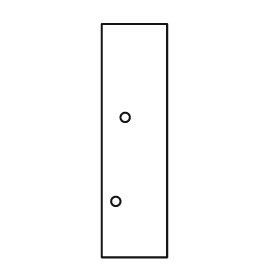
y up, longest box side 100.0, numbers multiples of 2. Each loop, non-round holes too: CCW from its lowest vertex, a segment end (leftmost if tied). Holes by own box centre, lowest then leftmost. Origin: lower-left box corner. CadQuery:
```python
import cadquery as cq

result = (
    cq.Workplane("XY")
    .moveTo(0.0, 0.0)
    .lineTo(28.0, 0.0)
    .lineTo(28.0, 100.0)
    .lineTo(0.0, 100.0)
    .close()
    .moveTo(6.0, 24.0)
    .circle(2.0)
    .moveTo(10.0, 60.0)
    .circle(2.0)
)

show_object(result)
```